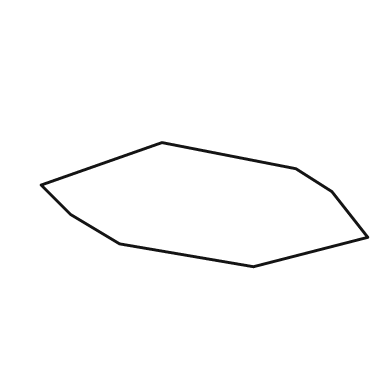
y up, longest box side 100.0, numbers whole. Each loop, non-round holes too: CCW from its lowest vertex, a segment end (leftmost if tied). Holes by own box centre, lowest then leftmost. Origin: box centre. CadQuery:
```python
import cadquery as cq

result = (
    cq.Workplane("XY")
    .moveTo(15.0, -19.0)
    .lineTo(50.0, -10.0)
    .lineTo(39.0, 4.0)
    .lineTo(28.0, 11.0)
    .lineTo(-13.0, 19.0)
    .lineTo(-50.0, 6.0)
    .lineTo(-41.0, -3.0)
    .lineTo(-26.0, -12.0)
    .close()
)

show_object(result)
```